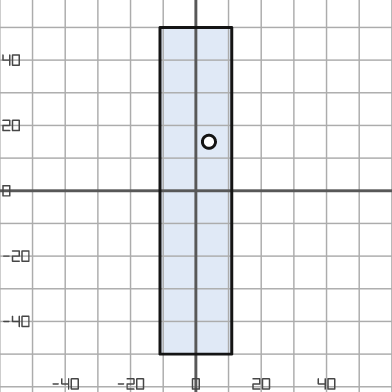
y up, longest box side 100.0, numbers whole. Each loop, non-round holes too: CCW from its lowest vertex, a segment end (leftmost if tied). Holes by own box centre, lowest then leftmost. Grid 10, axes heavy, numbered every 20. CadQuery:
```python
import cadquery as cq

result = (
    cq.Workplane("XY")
    .moveTo(-11.0, -50.0)
    .lineTo(11.0, -50.0)
    .lineTo(11.0, 50.0)
    .lineTo(-11.0, 50.0)
    .close()
    .moveTo(4.0, 15.0)
    .circle(2.0)
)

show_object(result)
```